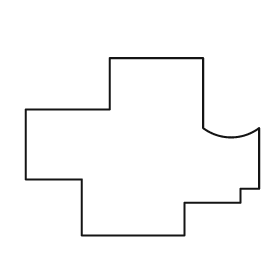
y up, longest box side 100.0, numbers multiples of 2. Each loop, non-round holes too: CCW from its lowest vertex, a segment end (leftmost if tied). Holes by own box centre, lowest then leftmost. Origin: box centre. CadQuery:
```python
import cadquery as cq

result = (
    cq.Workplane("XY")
    .moveTo(-26.0, -38.0)
    .lineTo(18.0, -38.0)
    .lineTo(18.0, -24.0)
    .lineTo(42.0, -24.0)
    .lineTo(42.0, -18.0)
    .lineTo(50.0, -18.0)
    .lineTo(50.0, 8.0)
    .threePointArc((38.0, 4.0), (26.0, 8.0))
    .lineTo(26.0, 38.0)
    .lineTo(-14.0, 38.0)
    .lineTo(-14.0, 16.0)
    .lineTo(-50.0, 16.0)
    .lineTo(-50.0, -14.0)
    .lineTo(-26.0, -14.0)
    .close()
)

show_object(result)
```